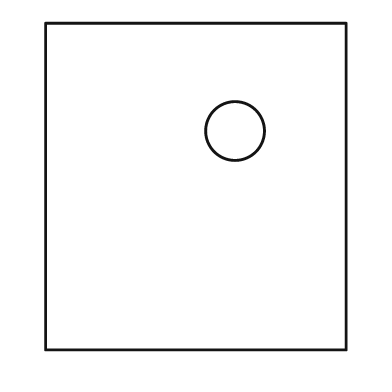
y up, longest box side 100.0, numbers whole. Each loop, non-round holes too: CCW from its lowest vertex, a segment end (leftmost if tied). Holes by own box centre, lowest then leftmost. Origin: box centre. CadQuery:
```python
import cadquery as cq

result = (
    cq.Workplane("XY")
    .moveTo(-46.0, -50.0)
    .lineTo(46.0, -50.0)
    .lineTo(46.0, 50.0)
    .lineTo(-46.0, 50.0)
    .close()
    .moveTo(12.0, 17.0)
    .circle(9.0)
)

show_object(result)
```